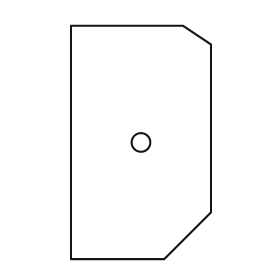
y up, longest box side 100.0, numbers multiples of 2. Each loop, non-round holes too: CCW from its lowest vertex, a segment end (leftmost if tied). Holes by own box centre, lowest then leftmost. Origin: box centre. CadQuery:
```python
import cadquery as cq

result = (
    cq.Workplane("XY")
    .moveTo(-30.0, -50.0)
    .lineTo(10.0, -50.0)
    .lineTo(30.0, -30.0)
    .lineTo(30.0, 42.0)
    .lineTo(18.0, 50.0)
    .lineTo(-30.0, 50.0)
    .close()
    .moveTo(0.0, 0.0)
    .circle(4.0)
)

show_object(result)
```